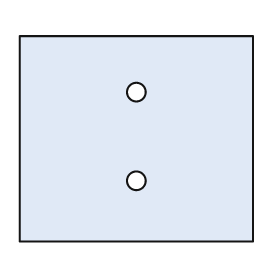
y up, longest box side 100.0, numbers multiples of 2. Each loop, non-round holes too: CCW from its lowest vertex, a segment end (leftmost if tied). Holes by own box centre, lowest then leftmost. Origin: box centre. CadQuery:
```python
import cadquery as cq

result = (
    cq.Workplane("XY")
    .moveTo(-50.0, -44.0)
    .lineTo(50.0, -44.0)
    .lineTo(50.0, 44.0)
    .lineTo(-50.0, 44.0)
    .close()
    .moveTo(0.0, -18.0)
    .circle(4.0)
    .moveTo(0.0, 20.0)
    .circle(4.0)
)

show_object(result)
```